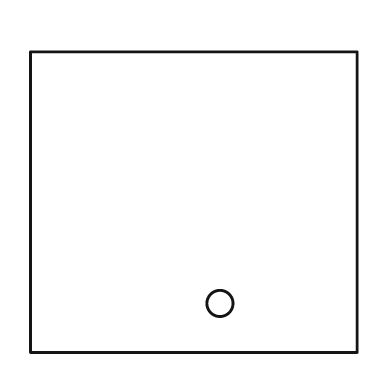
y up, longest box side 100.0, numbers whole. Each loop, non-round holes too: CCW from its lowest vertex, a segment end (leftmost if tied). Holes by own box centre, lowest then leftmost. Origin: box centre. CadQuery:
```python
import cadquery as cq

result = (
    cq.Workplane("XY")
    .moveTo(-50.0, -46.0)
    .lineTo(50.0, -46.0)
    .lineTo(50.0, 46.0)
    .lineTo(-50.0, 46.0)
    .close()
    .moveTo(8.0, -31.0)
    .circle(4.0)
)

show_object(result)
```